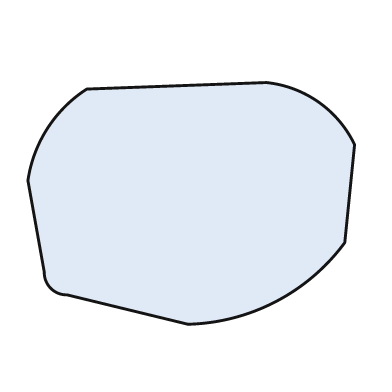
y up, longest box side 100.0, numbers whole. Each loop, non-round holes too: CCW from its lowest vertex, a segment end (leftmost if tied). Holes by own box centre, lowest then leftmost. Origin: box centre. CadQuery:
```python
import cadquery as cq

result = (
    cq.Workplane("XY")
    .moveTo(-1.0, -37.0)
    .threePointArc((26.0, -30.0), (47.0, -12.0))
    .lineTo(50.0, 18.0)
    .threePointArc((39.0, 31.0), (23.0, 37.0))
    .lineTo(-32.0, 35.0)
    .threePointArc((-44.0, 23.0), (-50.0, 7.0))
    .lineTo(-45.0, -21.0)
    .threePointArc((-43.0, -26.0), (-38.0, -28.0))
    .close()
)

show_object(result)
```